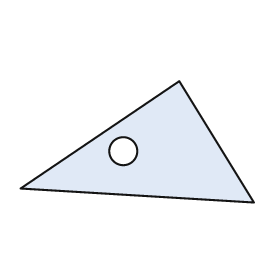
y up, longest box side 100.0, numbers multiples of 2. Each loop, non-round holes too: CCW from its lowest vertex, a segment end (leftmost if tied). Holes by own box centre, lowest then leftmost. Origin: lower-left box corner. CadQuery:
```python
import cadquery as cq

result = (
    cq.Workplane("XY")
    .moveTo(100.0, 0.0)
    .lineTo(68.0, 52.0)
    .lineTo(0.0, 6.0)
    .close()
    .moveTo(44.0, 22.0)
    .circle(6.0)
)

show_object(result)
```